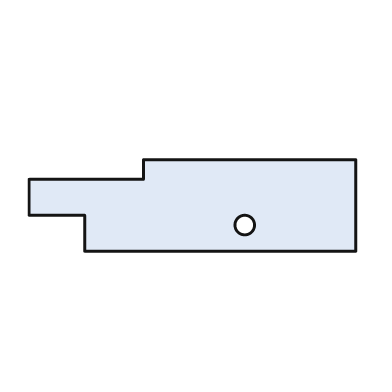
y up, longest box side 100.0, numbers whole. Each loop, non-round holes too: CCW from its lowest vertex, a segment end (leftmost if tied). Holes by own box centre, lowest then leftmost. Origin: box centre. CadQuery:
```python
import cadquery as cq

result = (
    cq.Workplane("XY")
    .moveTo(-33.0, -14.0)
    .lineTo(50.0, -14.0)
    .lineTo(50.0, 14.0)
    .lineTo(-15.0, 14.0)
    .lineTo(-15.0, 8.0)
    .lineTo(-50.0, 8.0)
    .lineTo(-50.0, -3.0)
    .lineTo(-33.0, -3.0)
    .close()
    .moveTo(16.0, -6.0)
    .circle(3.0)
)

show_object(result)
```